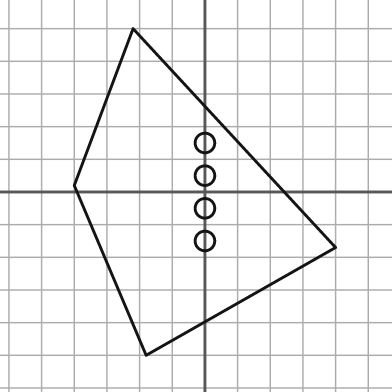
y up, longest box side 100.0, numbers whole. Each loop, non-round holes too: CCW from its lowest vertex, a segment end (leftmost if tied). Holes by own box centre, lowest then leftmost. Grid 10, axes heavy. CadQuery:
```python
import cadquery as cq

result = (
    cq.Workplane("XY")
    .moveTo(-18.0, -50.0)
    .lineTo(40.0, -17.0)
    .lineTo(-22.0, 50.0)
    .lineTo(-40.0, 2.0)
    .close()
    .moveTo(0.0, -15.0)
    .circle(3.0)
    .moveTo(0.0, -5.0)
    .circle(3.0)
    .moveTo(0.0, 5.0)
    .circle(3.0)
    .moveTo(0.0, 15.0)
    .circle(3.0)
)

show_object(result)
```